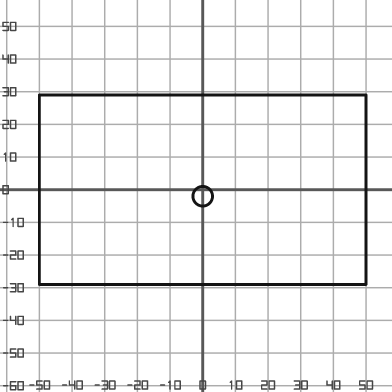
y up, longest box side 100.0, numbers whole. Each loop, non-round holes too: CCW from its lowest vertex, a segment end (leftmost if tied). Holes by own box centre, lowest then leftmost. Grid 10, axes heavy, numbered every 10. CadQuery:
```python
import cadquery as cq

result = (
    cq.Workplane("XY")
    .moveTo(-50.0, -29.0)
    .lineTo(50.0, -29.0)
    .lineTo(50.0, 29.0)
    .lineTo(-50.0, 29.0)
    .close()
    .moveTo(0.0, -2.0)
    .circle(3.0)
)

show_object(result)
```